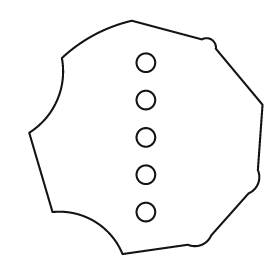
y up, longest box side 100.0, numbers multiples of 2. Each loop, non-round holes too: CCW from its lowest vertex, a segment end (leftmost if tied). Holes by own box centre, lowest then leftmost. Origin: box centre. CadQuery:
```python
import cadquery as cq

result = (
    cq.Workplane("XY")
    .moveTo(-10.0, -50.0)
    .lineTo(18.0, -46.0)
    .threePointArc((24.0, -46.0), (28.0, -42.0))
    .lineTo(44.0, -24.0)
    .threePointArc((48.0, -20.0), (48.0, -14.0))
    .lineTo(50.0, 14.0)
    .lineTo(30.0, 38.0)
    .threePointArc((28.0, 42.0), (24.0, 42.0))
    .lineTo(-6.0, 50.0)
    .threePointArc((-22.0, 44.0), (-36.0, 34.0))
    .threePointArc((-38.0, 16.0), (-50.0, 2.0))
    .lineTo(-40.0, -32.0)
    .threePointArc((-22.0, -36.0), (-10.0, -50.0))
    .close()
    .moveTo(0.0, -32.0)
    .circle(4.0)
    .moveTo(0.0, -16.0)
    .circle(4.0)
    .moveTo(0.0, 0.0)
    .circle(4.0)
    .moveTo(0.0, 16.0)
    .circle(4.0)
    .moveTo(0.0, 32.0)
    .circle(4.0)
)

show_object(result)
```